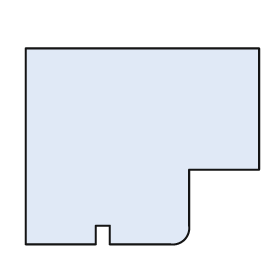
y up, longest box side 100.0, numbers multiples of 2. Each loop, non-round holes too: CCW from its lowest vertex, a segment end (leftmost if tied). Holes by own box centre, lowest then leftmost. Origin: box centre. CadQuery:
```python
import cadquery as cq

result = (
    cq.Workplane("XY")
    .moveTo(-50.0, -42.0)
    .lineTo(-20.0, -42.0)
    .lineTo(-20.0, -34.0)
    .lineTo(-14.0, -34.0)
    .lineTo(-14.0, -42.0)
    .lineTo(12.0, -42.0)
    .threePointArc((18.0, -40.0), (20.0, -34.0))
    .lineTo(20.0, -10.0)
    .lineTo(50.0, -10.0)
    .lineTo(50.0, 42.0)
    .lineTo(-50.0, 42.0)
    .close()
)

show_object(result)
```